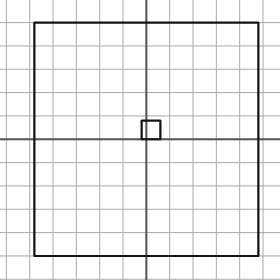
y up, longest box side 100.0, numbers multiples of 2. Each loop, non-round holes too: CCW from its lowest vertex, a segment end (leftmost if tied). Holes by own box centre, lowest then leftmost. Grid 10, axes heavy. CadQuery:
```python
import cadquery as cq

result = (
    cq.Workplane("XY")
    .moveTo(-48.0, -50.0)
    .lineTo(48.0, -50.0)
    .lineTo(48.0, 50.0)
    .lineTo(-48.0, 50.0)
    .close()
    .moveTo(-2.0, 0.0)
    .lineTo(6.0, 0.0)
    .lineTo(6.0, 8.0)
    .lineTo(-2.0, 8.0)
    .close()
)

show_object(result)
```